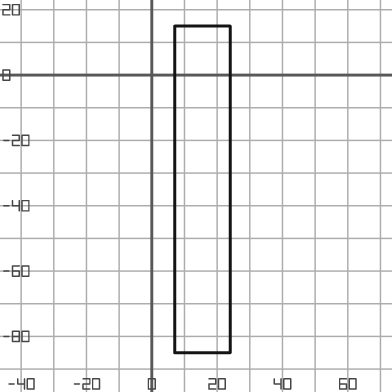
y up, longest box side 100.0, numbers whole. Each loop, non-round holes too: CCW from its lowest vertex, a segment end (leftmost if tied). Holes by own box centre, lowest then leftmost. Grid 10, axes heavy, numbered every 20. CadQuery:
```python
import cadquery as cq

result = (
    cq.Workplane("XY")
    .moveTo(7.0, -85.0)
    .lineTo(24.0, -85.0)
    .lineTo(24.0, 15.0)
    .lineTo(7.0, 15.0)
    .close()
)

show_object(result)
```